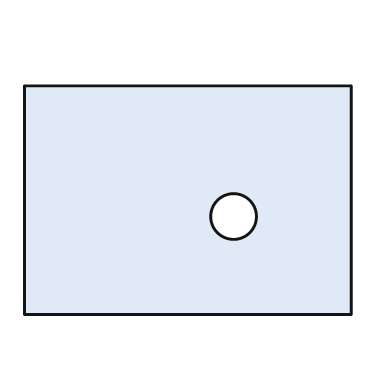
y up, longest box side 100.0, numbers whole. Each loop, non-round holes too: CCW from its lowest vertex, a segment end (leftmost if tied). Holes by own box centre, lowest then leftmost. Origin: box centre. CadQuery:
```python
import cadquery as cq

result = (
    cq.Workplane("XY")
    .moveTo(-50.0, -35.0)
    .lineTo(50.0, -35.0)
    .lineTo(50.0, 35.0)
    .lineTo(-50.0, 35.0)
    .close()
    .moveTo(14.0, -5.0)
    .circle(7.0)
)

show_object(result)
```